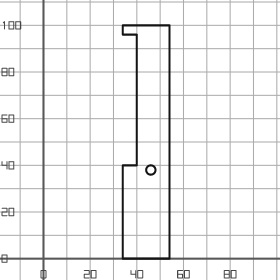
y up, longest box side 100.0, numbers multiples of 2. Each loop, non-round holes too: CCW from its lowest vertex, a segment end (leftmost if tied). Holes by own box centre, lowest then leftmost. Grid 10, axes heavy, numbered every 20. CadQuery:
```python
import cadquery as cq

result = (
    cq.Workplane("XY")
    .moveTo(34.0, 0.0)
    .lineTo(54.0, 0.0)
    .lineTo(54.0, 100.0)
    .lineTo(34.0, 100.0)
    .lineTo(34.0, 96.0)
    .lineTo(40.0, 96.0)
    .lineTo(40.0, 40.0)
    .lineTo(34.0, 40.0)
    .close()
    .moveTo(46.0, 38.0)
    .circle(2.0)
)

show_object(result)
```